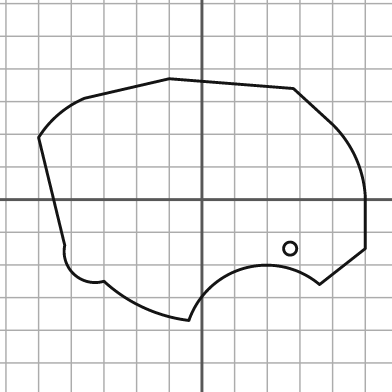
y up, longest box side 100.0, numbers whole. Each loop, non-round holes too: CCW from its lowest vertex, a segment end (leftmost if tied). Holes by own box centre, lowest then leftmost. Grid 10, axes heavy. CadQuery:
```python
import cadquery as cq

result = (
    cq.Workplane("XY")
    .moveTo(-4.0, -37.0)
    .threePointArc((13.0, -21.0), (36.0, -26.0))
    .lineTo(50.0, -15.0)
    .lineTo(50.0, 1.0)
    .threePointArc((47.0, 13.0), (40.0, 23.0))
    .lineTo(28.0, 34.0)
    .lineTo(-10.0, 37.0)
    .lineTo(-36.0, 31.0)
    .threePointArc((-44.0, 26.0), (-50.0, 19.0))
    .lineTo(-42.0, -14.0)
    .threePointArc((-39.0, -23.0), (-30.0, -25.0))
    .threePointArc((-18.0, -33.0), (-4.0, -37.0))
    .close()
    .moveTo(27.0, -15.0)
    .circle(2.0)
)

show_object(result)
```